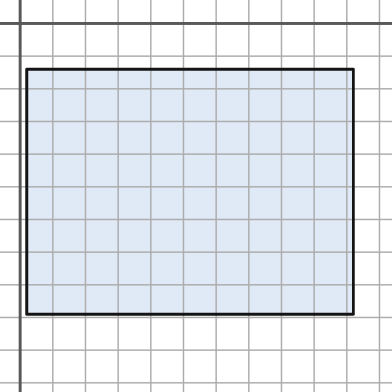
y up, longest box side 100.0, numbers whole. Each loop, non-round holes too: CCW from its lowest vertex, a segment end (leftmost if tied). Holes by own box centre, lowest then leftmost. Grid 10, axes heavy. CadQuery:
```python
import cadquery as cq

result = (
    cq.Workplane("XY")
    .moveTo(2.0, -89.0)
    .lineTo(102.0, -89.0)
    .lineTo(102.0, -14.0)
    .lineTo(2.0, -14.0)
    .close()
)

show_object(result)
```